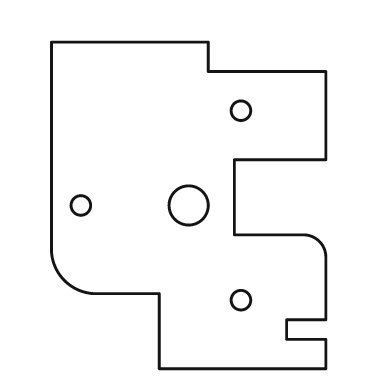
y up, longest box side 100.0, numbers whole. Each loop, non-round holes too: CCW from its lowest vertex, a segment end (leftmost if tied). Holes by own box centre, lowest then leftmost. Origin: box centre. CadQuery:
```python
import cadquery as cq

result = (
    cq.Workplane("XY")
    .moveTo(-9.0, -50.0)
    .lineTo(42.0, -50.0)
    .lineTo(42.0, -41.0)
    .lineTo(30.0, -41.0)
    .lineTo(30.0, -35.0)
    .lineTo(42.0, -35.0)
    .lineTo(42.0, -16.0)
    .threePointArc((40.0, -11.0), (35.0, -9.0))
    .lineTo(14.0, -9.0)
    .lineTo(14.0, 14.0)
    .lineTo(42.0, 14.0)
    .lineTo(42.0, 41.0)
    .lineTo(6.0, 41.0)
    .lineTo(6.0, 50.0)
    .lineTo(-42.0, 50.0)
    .lineTo(-42.0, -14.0)
    .threePointArc((-38.0, -23.0), (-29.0, -27.0))
    .lineTo(-9.0, -27.0)
    .close()
    .moveTo(16.0, -29.0)
    .circle(3.0)
    .moveTo(-33.0, 0.0)
    .circle(3.0)
    .moveTo(0.0, 0.0)
    .circle(6.0)
    .moveTo(16.0, 29.0)
    .circle(3.0)
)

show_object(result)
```